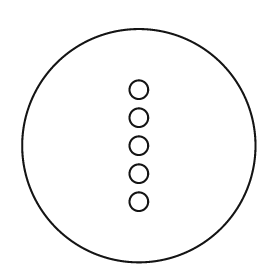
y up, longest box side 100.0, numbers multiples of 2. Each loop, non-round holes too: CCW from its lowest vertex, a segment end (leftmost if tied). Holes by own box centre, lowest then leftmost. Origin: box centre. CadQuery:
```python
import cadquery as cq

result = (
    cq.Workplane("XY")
    .moveTo(0.0, 0.0)
    .circle(50.0)
    .moveTo(0.0, -24.0)
    .circle(4.0)
    .moveTo(0.0, -12.0)
    .circle(4.0)
    .moveTo(0.0, 0.0)
    .circle(4.0)
    .moveTo(0.0, 12.0)
    .circle(4.0)
    .moveTo(0.0, 24.0)
    .circle(4.0)
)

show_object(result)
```